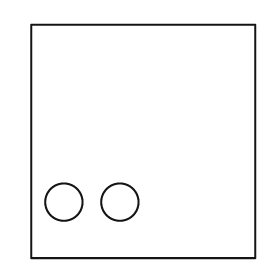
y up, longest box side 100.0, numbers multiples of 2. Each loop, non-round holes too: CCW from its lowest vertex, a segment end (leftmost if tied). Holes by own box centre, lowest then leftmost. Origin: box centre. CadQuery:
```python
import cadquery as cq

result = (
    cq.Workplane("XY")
    .moveTo(-48.0, -50.0)
    .lineTo(48.0, -50.0)
    .lineTo(48.0, 50.0)
    .lineTo(-48.0, 50.0)
    .close()
    .moveTo(-34.0, -26.0)
    .circle(8.0)
    .moveTo(-10.0, -26.0)
    .circle(8.0)
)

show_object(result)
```